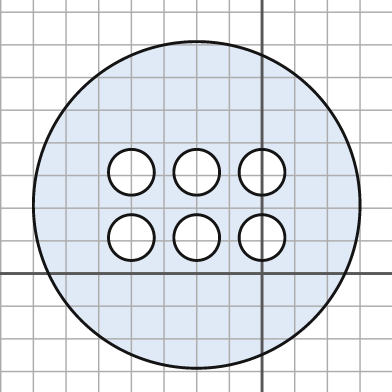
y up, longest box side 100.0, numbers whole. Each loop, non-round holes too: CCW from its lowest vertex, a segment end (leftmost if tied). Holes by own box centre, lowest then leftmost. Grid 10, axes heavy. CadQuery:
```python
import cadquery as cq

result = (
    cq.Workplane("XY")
    .moveTo(-20.0, 21.0)
    .circle(50.0)
    .moveTo(-40.0, 11.0)
    .circle(7.0)
    .moveTo(-20.0, 11.0)
    .circle(7.0)
    .moveTo(0.0, 11.0)
    .circle(7.0)
    .moveTo(-40.0, 31.0)
    .circle(7.0)
    .moveTo(-20.0, 31.0)
    .circle(7.0)
    .moveTo(0.0, 31.0)
    .circle(7.0)
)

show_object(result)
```